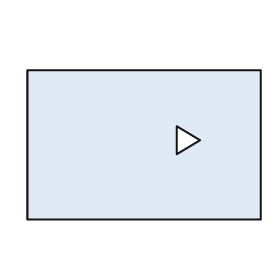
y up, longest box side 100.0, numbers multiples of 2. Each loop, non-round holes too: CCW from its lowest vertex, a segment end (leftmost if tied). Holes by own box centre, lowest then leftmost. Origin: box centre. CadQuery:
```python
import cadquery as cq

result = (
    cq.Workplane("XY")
    .moveTo(-50.0, -32.0)
    .lineTo(50.0, -32.0)
    .lineTo(50.0, 32.0)
    .lineTo(-50.0, 32.0)
    .close()
    .moveTo(14.0, -4.0)
    .lineTo(24.0, 2.0)
    .lineTo(14.0, 8.0)
    .close()
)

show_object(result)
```